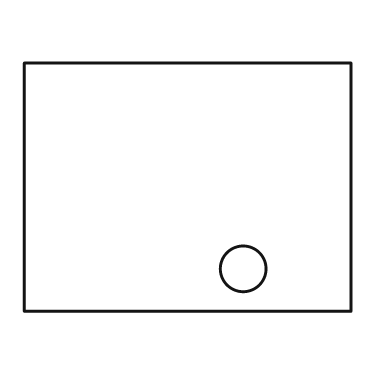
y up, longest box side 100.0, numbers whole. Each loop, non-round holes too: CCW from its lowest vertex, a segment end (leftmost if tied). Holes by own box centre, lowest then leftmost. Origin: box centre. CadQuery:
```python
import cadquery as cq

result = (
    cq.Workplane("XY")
    .moveTo(-50.0, -38.0)
    .lineTo(50.0, -38.0)
    .lineTo(50.0, 38.0)
    .lineTo(-50.0, 38.0)
    .close()
    .moveTo(17.0, -25.0)
    .circle(7.0)
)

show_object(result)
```